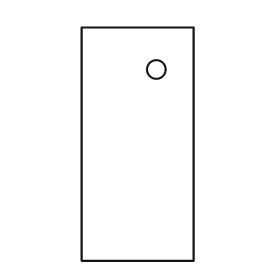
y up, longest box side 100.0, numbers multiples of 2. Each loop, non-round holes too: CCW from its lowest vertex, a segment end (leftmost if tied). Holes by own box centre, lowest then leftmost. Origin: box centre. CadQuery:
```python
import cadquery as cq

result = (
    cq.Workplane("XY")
    .moveTo(-24.0, -50.0)
    .lineTo(24.0, -50.0)
    .lineTo(24.0, 50.0)
    .lineTo(-24.0, 50.0)
    .close()
    .moveTo(8.0, 32.0)
    .circle(4.0)
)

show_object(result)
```